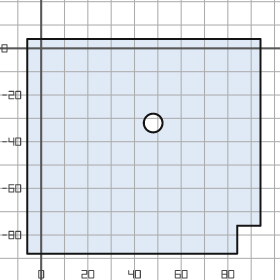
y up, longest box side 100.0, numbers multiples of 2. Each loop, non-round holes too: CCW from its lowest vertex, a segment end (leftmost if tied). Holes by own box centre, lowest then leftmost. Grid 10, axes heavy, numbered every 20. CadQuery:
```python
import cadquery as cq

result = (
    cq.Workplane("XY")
    .moveTo(-6.0, -88.0)
    .lineTo(84.0, -88.0)
    .lineTo(84.0, -76.0)
    .lineTo(94.0, -76.0)
    .lineTo(94.0, 4.0)
    .lineTo(-6.0, 4.0)
    .close()
    .moveTo(48.0, -32.0)
    .circle(4.0)
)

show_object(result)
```